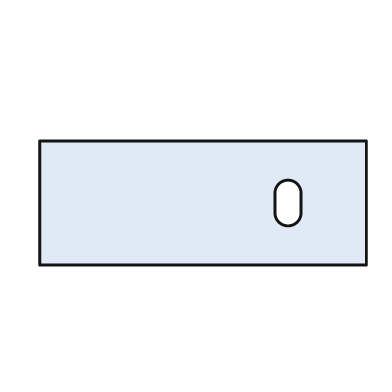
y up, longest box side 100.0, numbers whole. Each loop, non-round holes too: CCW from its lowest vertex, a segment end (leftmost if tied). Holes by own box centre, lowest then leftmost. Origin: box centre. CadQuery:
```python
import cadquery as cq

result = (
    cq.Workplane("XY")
    .moveTo(-50.0, -19.0)
    .lineTo(50.0, -19.0)
    .lineTo(50.0, 19.0)
    .lineTo(-50.0, 19.0)
    .close()
    .moveTo(22.0, -3.0)
    .threePointArc((26.0, -7.0), (30.0, -3.0))
    .lineTo(30.0, 3.0)
    .threePointArc((26.0, 7.0), (22.0, 3.0))
    .close()
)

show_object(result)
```